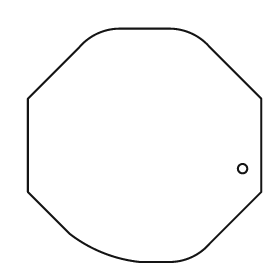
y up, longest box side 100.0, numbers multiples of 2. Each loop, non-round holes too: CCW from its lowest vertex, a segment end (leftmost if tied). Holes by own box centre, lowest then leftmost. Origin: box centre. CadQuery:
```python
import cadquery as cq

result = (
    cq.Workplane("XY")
    .moveTo(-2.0, -50.0)
    .lineTo(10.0, -50.0)
    .threePointArc((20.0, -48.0), (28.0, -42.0))
    .lineTo(50.0, -20.0)
    .lineTo(50.0, 20.0)
    .lineTo(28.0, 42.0)
    .threePointArc((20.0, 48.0), (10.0, 50.0))
    .lineTo(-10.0, 50.0)
    .threePointArc((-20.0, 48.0), (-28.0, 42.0))
    .lineTo(-50.0, 20.0)
    .lineTo(-50.0, -20.0)
    .lineTo(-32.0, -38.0)
    .threePointArc((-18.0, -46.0), (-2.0, -50.0))
    .close()
    .moveTo(42.0, -10.0)
    .circle(2.0)
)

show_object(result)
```